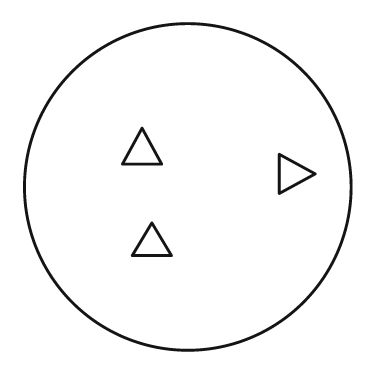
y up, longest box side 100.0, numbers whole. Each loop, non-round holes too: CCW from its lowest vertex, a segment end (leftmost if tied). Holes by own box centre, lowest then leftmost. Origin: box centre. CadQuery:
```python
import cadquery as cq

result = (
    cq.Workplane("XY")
    .moveTo(0.0, 0.0)
    .circle(50.0)
    .moveTo(-17.0, -21.0)
    .lineTo(-5.0, -21.0)
    .lineTo(-11.0, -11.0)
    .close()
    .moveTo(28.0, -2.0)
    .lineTo(39.0, 4.0)
    .lineTo(28.0, 10.0)
    .close()
    .moveTo(-20.0, 7.0)
    .lineTo(-8.0, 7.0)
    .lineTo(-14.0, 18.0)
    .close()
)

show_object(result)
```